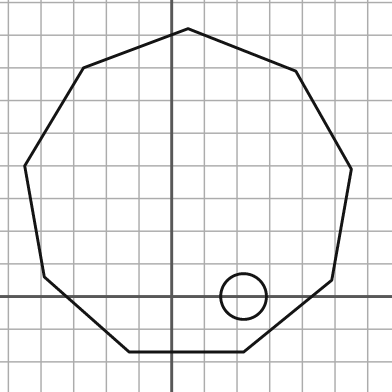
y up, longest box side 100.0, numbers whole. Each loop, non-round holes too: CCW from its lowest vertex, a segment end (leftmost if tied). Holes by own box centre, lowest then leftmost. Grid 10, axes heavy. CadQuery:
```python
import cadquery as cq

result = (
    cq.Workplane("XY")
    .moveTo(-13.0, -17.0)
    .lineTo(22.0, -17.0)
    .lineTo(49.0, 5.0)
    .lineTo(55.0, 39.0)
    .lineTo(38.0, 69.0)
    .lineTo(5.0, 82.0)
    .lineTo(-27.0, 70.0)
    .lineTo(-45.0, 40.0)
    .lineTo(-39.0, 6.0)
    .close()
    .moveTo(22.0, 0.0)
    .circle(7.0)
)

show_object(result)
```